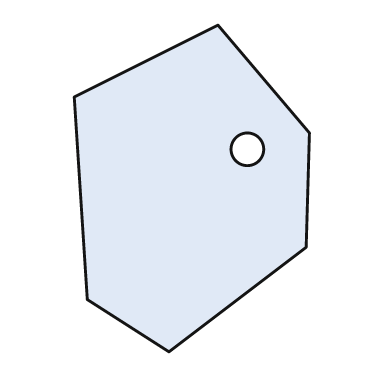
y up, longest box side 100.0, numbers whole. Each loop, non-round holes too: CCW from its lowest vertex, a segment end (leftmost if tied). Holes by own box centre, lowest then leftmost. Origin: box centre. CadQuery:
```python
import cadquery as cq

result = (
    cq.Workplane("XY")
    .moveTo(-7.0, -50.0)
    .lineTo(35.0, -18.0)
    .lineTo(36.0, 17.0)
    .lineTo(8.0, 50.0)
    .lineTo(-36.0, 28.0)
    .lineTo(-32.0, -34.0)
    .close()
    .moveTo(17.0, 12.0)
    .circle(5.0)
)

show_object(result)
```